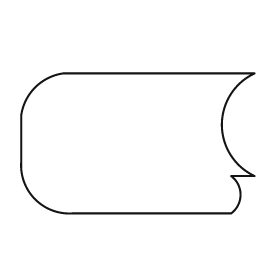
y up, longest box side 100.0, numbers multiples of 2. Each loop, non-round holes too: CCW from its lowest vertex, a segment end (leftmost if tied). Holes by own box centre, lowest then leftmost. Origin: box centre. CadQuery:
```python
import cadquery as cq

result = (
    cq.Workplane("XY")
    .moveTo(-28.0, -30.0)
    .lineTo(40.0, -30.0)
    .threePointArc((44.0, -22.0), (40.0, -14.0))
    .lineTo(50.0, -14.0)
    .threePointArc((36.0, 8.0), (50.0, 30.0))
    .lineTo(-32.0, 30.0)
    .threePointArc((-44.0, 24.0), (-50.0, 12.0))
    .lineTo(-50.0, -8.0)
    .threePointArc((-44.0, -24.0), (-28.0, -30.0))
    .close()
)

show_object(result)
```